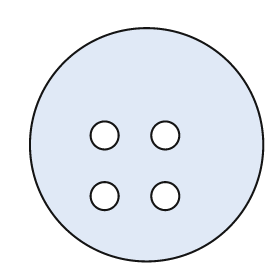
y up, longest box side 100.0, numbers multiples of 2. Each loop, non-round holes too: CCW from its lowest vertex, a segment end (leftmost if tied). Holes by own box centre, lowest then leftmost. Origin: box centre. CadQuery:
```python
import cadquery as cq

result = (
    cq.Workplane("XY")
    .moveTo(0.0, 0.0)
    .circle(50.0)
    .moveTo(-18.0, -22.0)
    .circle(6.0)
    .moveTo(8.0, -22.0)
    .circle(6.0)
    .moveTo(-18.0, 4.0)
    .circle(6.0)
    .moveTo(8.0, 4.0)
    .circle(6.0)
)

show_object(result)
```